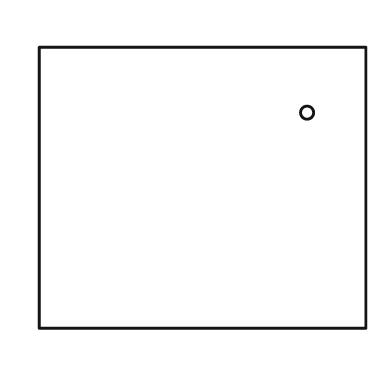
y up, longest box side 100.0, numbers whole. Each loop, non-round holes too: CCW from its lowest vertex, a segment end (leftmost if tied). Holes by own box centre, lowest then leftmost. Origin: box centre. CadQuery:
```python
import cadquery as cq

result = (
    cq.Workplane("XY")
    .moveTo(-50.0, -43.0)
    .lineTo(50.0, -43.0)
    .lineTo(50.0, 43.0)
    .lineTo(-50.0, 43.0)
    .close()
    .moveTo(32.0, 23.0)
    .circle(2.0)
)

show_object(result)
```